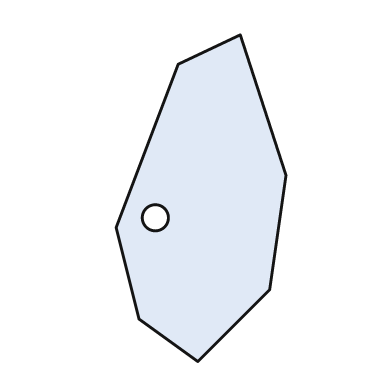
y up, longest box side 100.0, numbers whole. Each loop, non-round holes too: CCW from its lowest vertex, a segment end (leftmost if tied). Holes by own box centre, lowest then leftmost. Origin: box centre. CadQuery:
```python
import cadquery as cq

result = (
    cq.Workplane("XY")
    .moveTo(-1.0, -50.0)
    .lineTo(21.0, -28.0)
    .lineTo(26.0, 7.0)
    .lineTo(12.0, 50.0)
    .lineTo(-7.0, 41.0)
    .lineTo(-26.0, -9.0)
    .lineTo(-19.0, -37.0)
    .close()
    .moveTo(-14.0, -6.0)
    .circle(4.0)
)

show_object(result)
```